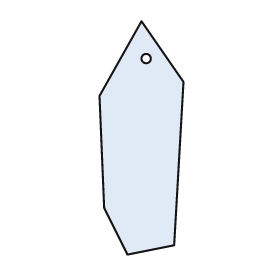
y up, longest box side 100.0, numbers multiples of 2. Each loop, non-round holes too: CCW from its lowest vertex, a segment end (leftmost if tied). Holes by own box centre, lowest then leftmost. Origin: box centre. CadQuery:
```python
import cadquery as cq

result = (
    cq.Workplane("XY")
    .moveTo(-6.0, -50.0)
    .lineTo(14.0, -46.0)
    .lineTo(18.0, 24.0)
    .lineTo(0.0, 50.0)
    .lineTo(-18.0, 18.0)
    .lineTo(-16.0, -30.0)
    .close()
    .moveTo(2.0, 34.0)
    .circle(2.0)
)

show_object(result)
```